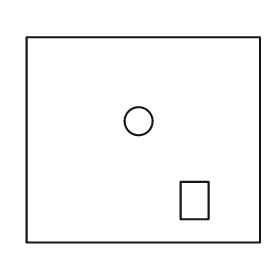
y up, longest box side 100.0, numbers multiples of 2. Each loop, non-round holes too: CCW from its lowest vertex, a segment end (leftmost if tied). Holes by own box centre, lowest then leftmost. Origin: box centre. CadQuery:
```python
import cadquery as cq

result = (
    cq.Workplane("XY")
    .moveTo(-50.0, -44.0)
    .lineTo(50.0, -44.0)
    .lineTo(50.0, 44.0)
    .lineTo(-50.0, 44.0)
    .close()
    .moveTo(16.0, -34.0)
    .lineTo(28.0, -34.0)
    .lineTo(28.0, -18.0)
    .lineTo(16.0, -18.0)
    .close()
    .moveTo(-2.0, 8.0)
    .circle(6.0)
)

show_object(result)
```